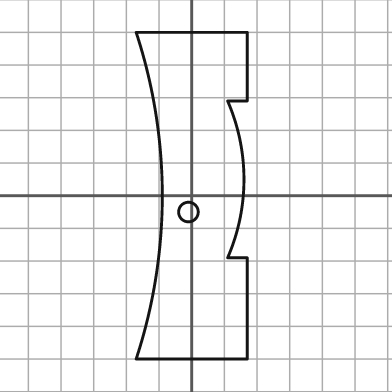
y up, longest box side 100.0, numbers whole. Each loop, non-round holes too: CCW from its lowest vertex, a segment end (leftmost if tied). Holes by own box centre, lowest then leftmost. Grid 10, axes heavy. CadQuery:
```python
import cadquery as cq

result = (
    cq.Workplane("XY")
    .moveTo(-17.0, -50.0)
    .lineTo(17.0, -50.0)
    .lineTo(17.0, -19.0)
    .lineTo(11.0, -19.0)
    .threePointArc((16.0, 5.0), (11.0, 29.0))
    .lineTo(17.0, 29.0)
    .lineTo(17.0, 50.0)
    .lineTo(-17.0, 50.0)
    .threePointArc((-9.0, 0.0), (-17.0, -50.0))
    .close()
    .moveTo(-1.0, -5.0)
    .circle(3.0)
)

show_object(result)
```